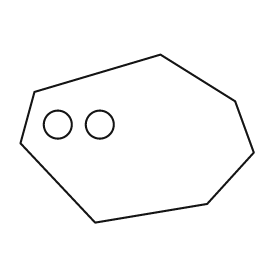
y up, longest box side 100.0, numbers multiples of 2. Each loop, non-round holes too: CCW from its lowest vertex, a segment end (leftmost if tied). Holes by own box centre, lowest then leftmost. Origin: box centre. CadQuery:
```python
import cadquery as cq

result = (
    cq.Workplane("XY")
    .moveTo(-18.0, -36.0)
    .lineTo(30.0, -28.0)
    .lineTo(50.0, -6.0)
    .lineTo(42.0, 16.0)
    .lineTo(10.0, 36.0)
    .lineTo(-44.0, 20.0)
    .lineTo(-50.0, -2.0)
    .close()
    .moveTo(-34.0, 6.0)
    .circle(6.0)
    .moveTo(-16.0, 6.0)
    .circle(6.0)
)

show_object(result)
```